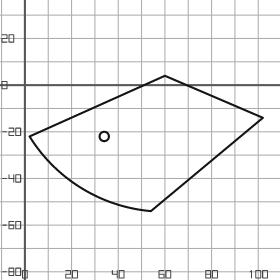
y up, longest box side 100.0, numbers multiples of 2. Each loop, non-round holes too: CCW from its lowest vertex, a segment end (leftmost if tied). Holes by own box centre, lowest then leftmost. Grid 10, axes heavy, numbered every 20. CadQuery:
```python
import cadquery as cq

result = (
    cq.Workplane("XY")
    .moveTo(54.0, -54.0)
    .lineTo(102.0, -14.0)
    .lineTo(60.0, 4.0)
    .lineTo(2.0, -22.0)
    .threePointArc((24.0, -44.0), (54.0, -54.0))
    .close()
    .moveTo(34.0, -22.0)
    .circle(2.0)
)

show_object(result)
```